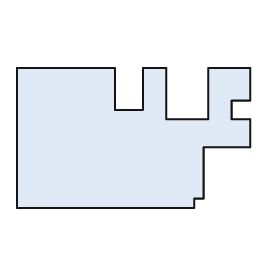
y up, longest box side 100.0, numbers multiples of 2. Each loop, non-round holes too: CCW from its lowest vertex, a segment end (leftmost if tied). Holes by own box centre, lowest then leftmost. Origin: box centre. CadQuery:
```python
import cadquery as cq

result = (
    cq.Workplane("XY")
    .moveTo(-50.0, -30.0)
    .lineTo(26.0, -30.0)
    .lineTo(26.0, -26.0)
    .lineTo(30.0, -26.0)
    .lineTo(30.0, -4.0)
    .lineTo(50.0, -4.0)
    .lineTo(50.0, 8.0)
    .lineTo(42.0, 8.0)
    .lineTo(42.0, 16.0)
    .lineTo(50.0, 16.0)
    .lineTo(50.0, 30.0)
    .lineTo(32.0, 30.0)
    .lineTo(32.0, 8.0)
    .lineTo(14.0, 8.0)
    .lineTo(14.0, 30.0)
    .lineTo(4.0, 30.0)
    .lineTo(4.0, 12.0)
    .lineTo(-8.0, 12.0)
    .lineTo(-8.0, 30.0)
    .lineTo(-50.0, 30.0)
    .close()
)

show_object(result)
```